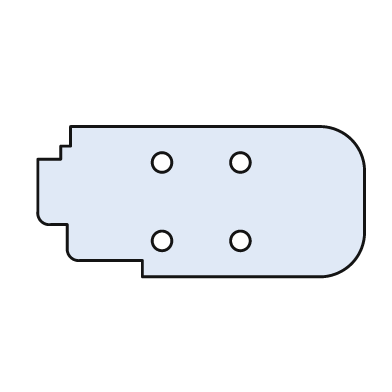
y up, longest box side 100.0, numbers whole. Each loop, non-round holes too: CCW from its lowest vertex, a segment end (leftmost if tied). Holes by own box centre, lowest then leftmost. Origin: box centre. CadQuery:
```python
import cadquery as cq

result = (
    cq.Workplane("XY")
    .moveTo(-18.0, -23.0)
    .lineTo(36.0, -23.0)
    .threePointArc((46.0, -19.0), (50.0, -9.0))
    .lineTo(50.0, 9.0)
    .threePointArc((46.0, 19.0), (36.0, 23.0))
    .lineTo(-40.0, 23.0)
    .lineTo(-40.0, 17.0)
    .lineTo(-43.0, 17.0)
    .lineTo(-43.0, 13.0)
    .lineTo(-50.0, 13.0)
    .lineTo(-50.0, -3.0)
    .threePointArc((-49.0, -6.0), (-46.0, -7.0))
    .lineTo(-41.0, -7.0)
    .lineTo(-41.0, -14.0)
    .threePointArc((-40.0, -17.0), (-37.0, -18.0))
    .lineTo(-18.0, -18.0)
    .close()
    .moveTo(-12.0, -12.0)
    .circle(3.0)
    .moveTo(12.0, -12.0)
    .circle(3.0)
    .moveTo(-12.0, 12.0)
    .circle(3.0)
    .moveTo(12.0, 12.0)
    .circle(3.0)
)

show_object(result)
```